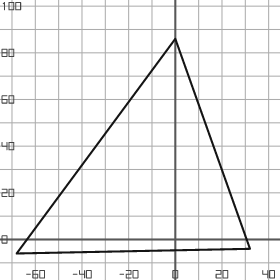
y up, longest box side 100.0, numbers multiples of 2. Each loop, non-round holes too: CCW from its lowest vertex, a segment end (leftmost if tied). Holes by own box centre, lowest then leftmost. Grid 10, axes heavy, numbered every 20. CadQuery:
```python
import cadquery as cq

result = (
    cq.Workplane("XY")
    .moveTo(-68.0, -6.0)
    .lineTo(32.0, -4.0)
    .lineTo(0.0, 86.0)
    .close()
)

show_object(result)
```